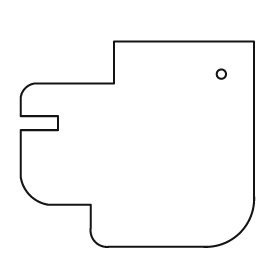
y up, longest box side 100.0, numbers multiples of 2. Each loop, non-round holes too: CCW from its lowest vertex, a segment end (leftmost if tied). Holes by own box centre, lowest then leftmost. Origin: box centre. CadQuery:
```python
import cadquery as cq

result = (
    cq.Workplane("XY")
    .moveTo(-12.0, -44.0)
    .lineTo(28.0, -44.0)
    .threePointArc((44.0, -38.0), (50.0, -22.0))
    .lineTo(50.0, 44.0)
    .lineTo(-10.0, 44.0)
    .lineTo(-10.0, 26.0)
    .lineTo(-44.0, 26.0)
    .threePointArc((-48.0, 24.0), (-50.0, 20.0))
    .lineTo(-50.0, 12.0)
    .lineTo(-34.0, 12.0)
    .lineTo(-34.0, 6.0)
    .lineTo(-50.0, 6.0)
    .lineTo(-50.0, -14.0)
    .threePointArc((-46.0, -22.0), (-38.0, -26.0))
    .lineTo(-20.0, -26.0)
    .lineTo(-20.0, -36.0)
    .threePointArc((-18.0, -42.0), (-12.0, -44.0))
    .close()
    .moveTo(36.0, 30.0)
    .circle(2.0)
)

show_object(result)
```